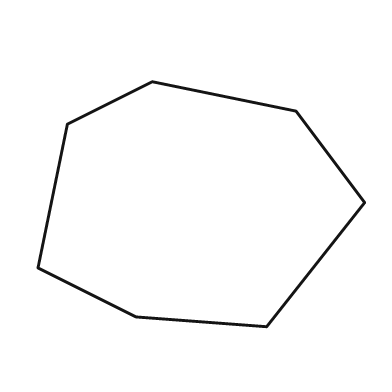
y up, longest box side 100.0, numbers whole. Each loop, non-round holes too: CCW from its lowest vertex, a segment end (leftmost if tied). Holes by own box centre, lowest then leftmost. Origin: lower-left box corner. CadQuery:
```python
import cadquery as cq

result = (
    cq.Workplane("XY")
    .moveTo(70.0, 0.0)
    .lineTo(100.0, 38.0)
    .lineTo(79.0, 66.0)
    .lineTo(35.0, 75.0)
    .lineTo(9.0, 62.0)
    .lineTo(0.0, 18.0)
    .lineTo(30.0, 3.0)
    .close()
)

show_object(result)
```